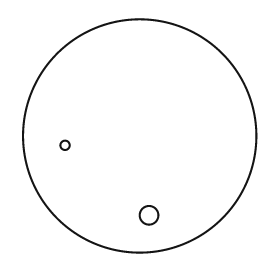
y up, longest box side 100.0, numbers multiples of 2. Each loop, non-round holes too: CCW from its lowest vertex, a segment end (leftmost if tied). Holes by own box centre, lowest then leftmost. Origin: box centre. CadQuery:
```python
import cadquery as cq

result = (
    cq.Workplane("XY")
    .moveTo(0.0, 0.0)
    .circle(50.0)
    .moveTo(4.0, -34.0)
    .circle(4.0)
    .moveTo(-32.0, -4.0)
    .circle(2.0)
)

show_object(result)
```